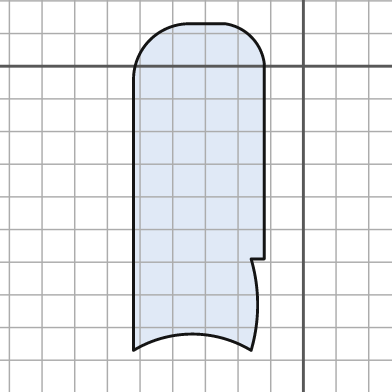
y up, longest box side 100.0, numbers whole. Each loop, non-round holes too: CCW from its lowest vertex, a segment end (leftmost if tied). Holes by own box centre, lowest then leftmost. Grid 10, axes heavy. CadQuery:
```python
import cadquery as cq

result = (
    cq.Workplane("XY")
    .moveTo(-52.0, -87.0)
    .threePointArc((-34.0, -82.0), (-16.0, -87.0))
    .threePointArc((-14.0, -73.0), (-16.0, -59.0))
    .lineTo(-12.0, -59.0)
    .lineTo(-12.0, 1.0)
    .threePointArc((-16.0, 9.0), (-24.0, 13.0))
    .lineTo(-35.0, 13.0)
    .threePointArc((-47.0, 8.0), (-52.0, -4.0))
    .close()
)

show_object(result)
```